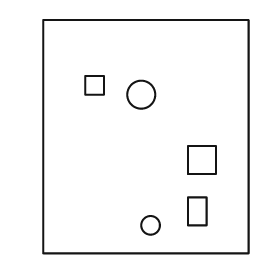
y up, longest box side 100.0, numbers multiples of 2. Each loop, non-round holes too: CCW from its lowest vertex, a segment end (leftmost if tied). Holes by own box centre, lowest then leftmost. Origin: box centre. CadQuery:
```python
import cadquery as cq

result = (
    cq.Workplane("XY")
    .moveTo(-44.0, -50.0)
    .lineTo(44.0, -50.0)
    .lineTo(44.0, 50.0)
    .lineTo(-44.0, 50.0)
    .close()
    .moveTo(2.0, -38.0)
    .circle(4.0)
    .moveTo(18.0, -38.0)
    .lineTo(26.0, -38.0)
    .lineTo(26.0, -26.0)
    .lineTo(18.0, -26.0)
    .close()
    .moveTo(18.0, -16.0)
    .lineTo(30.0, -16.0)
    .lineTo(30.0, -4.0)
    .lineTo(18.0, -4.0)
    .close()
    .moveTo(-2.0, 18.0)
    .circle(6.0)
    .moveTo(-26.0, 18.0)
    .lineTo(-18.0, 18.0)
    .lineTo(-18.0, 26.0)
    .lineTo(-26.0, 26.0)
    .close()
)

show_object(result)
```